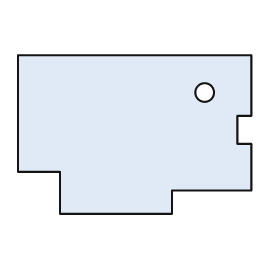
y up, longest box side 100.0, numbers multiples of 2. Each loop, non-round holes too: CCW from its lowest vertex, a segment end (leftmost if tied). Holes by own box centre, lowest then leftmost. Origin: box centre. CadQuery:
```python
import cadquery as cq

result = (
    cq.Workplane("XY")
    .moveTo(-32.0, -34.0)
    .lineTo(16.0, -34.0)
    .lineTo(16.0, -24.0)
    .lineTo(50.0, -24.0)
    .lineTo(50.0, -4.0)
    .lineTo(44.0, -4.0)
    .lineTo(44.0, 8.0)
    .lineTo(50.0, 8.0)
    .lineTo(50.0, 34.0)
    .lineTo(-50.0, 34.0)
    .lineTo(-50.0, -16.0)
    .lineTo(-32.0, -16.0)
    .close()
    .moveTo(30.0, 18.0)
    .circle(4.0)
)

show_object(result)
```